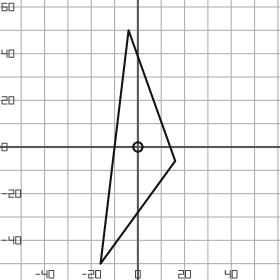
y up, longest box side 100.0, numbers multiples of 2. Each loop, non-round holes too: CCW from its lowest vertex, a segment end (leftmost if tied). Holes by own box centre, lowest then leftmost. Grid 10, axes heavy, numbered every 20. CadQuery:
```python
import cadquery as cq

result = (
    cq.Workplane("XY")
    .moveTo(-16.0, -50.0)
    .lineTo(16.0, -6.0)
    .lineTo(-4.0, 50.0)
    .close()
    .moveTo(0.0, 0.0)
    .circle(2.0)
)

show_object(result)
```